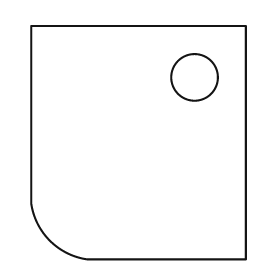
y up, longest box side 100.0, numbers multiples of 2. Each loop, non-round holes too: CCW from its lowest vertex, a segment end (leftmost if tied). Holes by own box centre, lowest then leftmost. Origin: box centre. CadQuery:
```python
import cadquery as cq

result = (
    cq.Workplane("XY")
    .moveTo(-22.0, -50.0)
    .lineTo(46.0, -50.0)
    .lineTo(46.0, 50.0)
    .lineTo(-46.0, 50.0)
    .lineTo(-46.0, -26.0)
    .threePointArc((-38.0, -42.0), (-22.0, -50.0))
    .close()
    .moveTo(24.0, 28.0)
    .circle(10.0)
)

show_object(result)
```